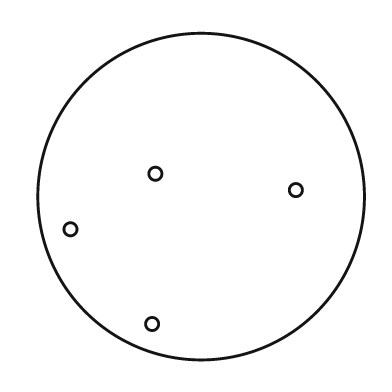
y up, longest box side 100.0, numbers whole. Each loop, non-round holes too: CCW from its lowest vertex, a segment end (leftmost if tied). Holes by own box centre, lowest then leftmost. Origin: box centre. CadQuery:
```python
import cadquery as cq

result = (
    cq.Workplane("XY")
    .moveTo(0.0, 0.0)
    .circle(50.0)
    .moveTo(-15.0, -39.0)
    .circle(2.0)
    .moveTo(-40.0, -10.0)
    .circle(2.0)
    .moveTo(29.0, 2.0)
    .circle(2.0)
    .moveTo(-14.0, 7.0)
    .circle(2.0)
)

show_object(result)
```